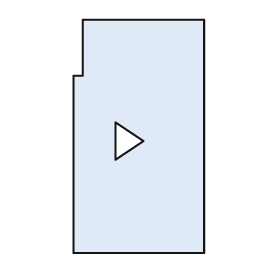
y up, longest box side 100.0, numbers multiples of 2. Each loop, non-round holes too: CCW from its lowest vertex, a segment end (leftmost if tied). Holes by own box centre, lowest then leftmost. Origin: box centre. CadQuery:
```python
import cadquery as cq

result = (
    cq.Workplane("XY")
    .moveTo(-28.0, -50.0)
    .lineTo(28.0, -50.0)
    .lineTo(28.0, 50.0)
    .lineTo(-24.0, 50.0)
    .lineTo(-24.0, 26.0)
    .lineTo(-28.0, 26.0)
    .close()
    .moveTo(-10.0, -10.0)
    .lineTo(2.0, -2.0)
    .lineTo(-10.0, 6.0)
    .close()
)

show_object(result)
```